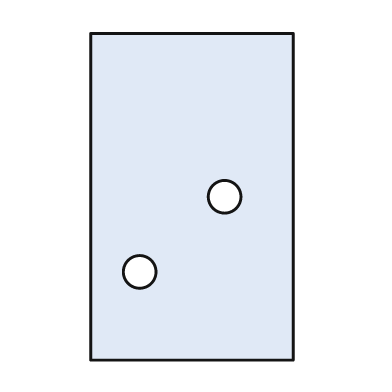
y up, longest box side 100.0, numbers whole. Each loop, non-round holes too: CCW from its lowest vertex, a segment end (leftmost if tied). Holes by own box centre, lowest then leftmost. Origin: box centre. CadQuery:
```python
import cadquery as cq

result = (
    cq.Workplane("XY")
    .moveTo(-31.0, -50.0)
    .lineTo(31.0, -50.0)
    .lineTo(31.0, 50.0)
    .lineTo(-31.0, 50.0)
    .close()
    .moveTo(-16.0, -23.0)
    .circle(5.0)
    .moveTo(10.0, 0.0)
    .circle(5.0)
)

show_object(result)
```